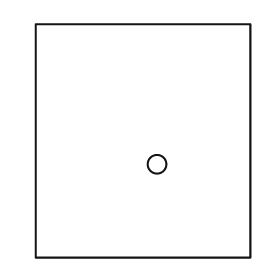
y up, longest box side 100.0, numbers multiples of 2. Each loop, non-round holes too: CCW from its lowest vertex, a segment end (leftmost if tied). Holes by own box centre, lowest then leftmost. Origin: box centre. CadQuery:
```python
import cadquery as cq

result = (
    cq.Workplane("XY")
    .moveTo(-46.0, -50.0)
    .lineTo(46.0, -50.0)
    .lineTo(46.0, 50.0)
    .lineTo(-46.0, 50.0)
    .close()
    .moveTo(6.0, -10.0)
    .circle(4.0)
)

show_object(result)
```